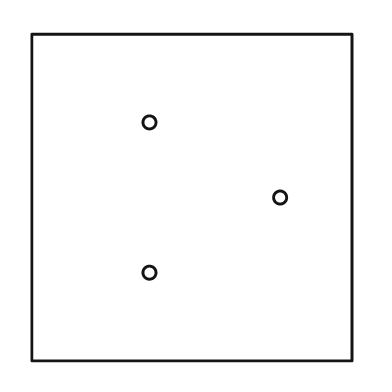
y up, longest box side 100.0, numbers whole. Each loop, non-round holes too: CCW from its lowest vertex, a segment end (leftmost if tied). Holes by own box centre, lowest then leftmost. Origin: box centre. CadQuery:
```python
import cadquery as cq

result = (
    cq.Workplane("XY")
    .moveTo(-49.0, -50.0)
    .lineTo(49.0, -50.0)
    .lineTo(49.0, 50.0)
    .lineTo(-49.0, 50.0)
    .close()
    .moveTo(-13.0, -23.0)
    .circle(2.0)
    .moveTo(27.0, 0.0)
    .circle(2.0)
    .moveTo(-13.0, 23.0)
    .circle(2.0)
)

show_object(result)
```